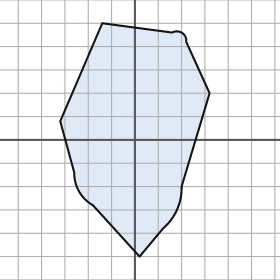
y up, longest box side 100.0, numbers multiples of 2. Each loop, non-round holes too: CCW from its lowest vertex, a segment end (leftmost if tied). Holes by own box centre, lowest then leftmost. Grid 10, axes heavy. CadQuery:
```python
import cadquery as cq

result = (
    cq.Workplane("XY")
    .moveTo(2.0, -50.0)
    .lineTo(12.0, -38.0)
    .threePointArc((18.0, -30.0), (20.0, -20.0))
    .lineTo(32.0, 20.0)
    .lineTo(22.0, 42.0)
    .threePointArc((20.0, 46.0), (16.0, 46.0))
    .lineTo(-14.0, 50.0)
    .lineTo(-32.0, 8.0)
    .lineTo(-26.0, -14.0)
    .threePointArc((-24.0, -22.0), (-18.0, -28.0))
    .close()
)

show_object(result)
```